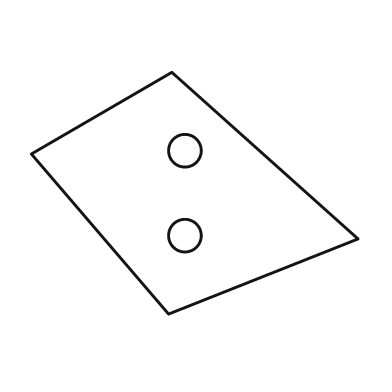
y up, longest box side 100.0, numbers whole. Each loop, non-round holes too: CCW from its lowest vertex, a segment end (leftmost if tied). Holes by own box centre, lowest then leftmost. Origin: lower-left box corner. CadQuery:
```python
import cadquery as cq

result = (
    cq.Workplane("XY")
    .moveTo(42.0, 0.0)
    .lineTo(100.0, 23.0)
    .lineTo(43.0, 74.0)
    .lineTo(0.0, 49.0)
    .close()
    .moveTo(47.0, 24.0)
    .circle(5.0)
    .moveTo(47.0, 50.0)
    .circle(5.0)
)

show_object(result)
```